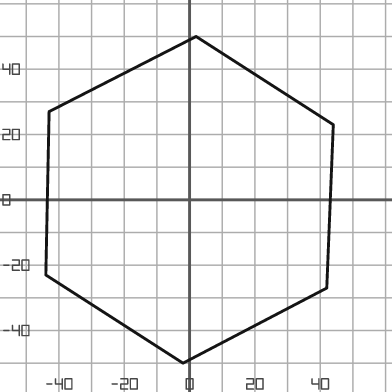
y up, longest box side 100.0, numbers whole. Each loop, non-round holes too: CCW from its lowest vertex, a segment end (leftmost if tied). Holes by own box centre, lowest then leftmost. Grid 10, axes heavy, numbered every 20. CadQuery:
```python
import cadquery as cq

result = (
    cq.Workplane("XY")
    .moveTo(-2.0, -50.0)
    .lineTo(42.0, -27.0)
    .lineTo(44.0, 23.0)
    .lineTo(2.0, 50.0)
    .lineTo(-43.0, 27.0)
    .lineTo(-44.0, -23.0)
    .close()
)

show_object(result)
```